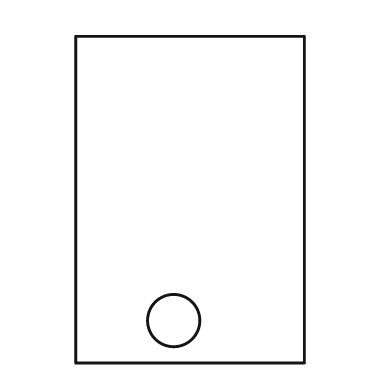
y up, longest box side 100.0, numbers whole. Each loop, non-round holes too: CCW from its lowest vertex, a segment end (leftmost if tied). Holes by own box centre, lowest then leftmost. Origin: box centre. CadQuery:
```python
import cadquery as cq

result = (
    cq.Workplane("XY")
    .moveTo(-35.0, -50.0)
    .lineTo(35.0, -50.0)
    .lineTo(35.0, 50.0)
    .lineTo(-35.0, 50.0)
    .close()
    .moveTo(-5.0, -37.0)
    .circle(8.0)
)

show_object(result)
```